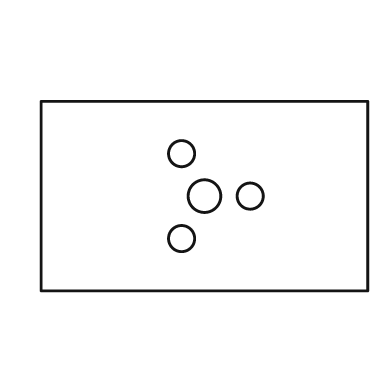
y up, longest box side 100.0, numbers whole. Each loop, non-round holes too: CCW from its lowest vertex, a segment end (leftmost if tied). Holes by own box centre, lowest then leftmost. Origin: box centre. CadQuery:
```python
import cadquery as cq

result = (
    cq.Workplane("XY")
    .moveTo(-50.0, -29.0)
    .lineTo(50.0, -29.0)
    .lineTo(50.0, 29.0)
    .lineTo(-50.0, 29.0)
    .close()
    .moveTo(-7.0, -13.0)
    .circle(4.0)
    .moveTo(0.0, 0.0)
    .circle(5.0)
    .moveTo(14.0, 0.0)
    .circle(4.0)
    .moveTo(-7.0, 13.0)
    .circle(4.0)
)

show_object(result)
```